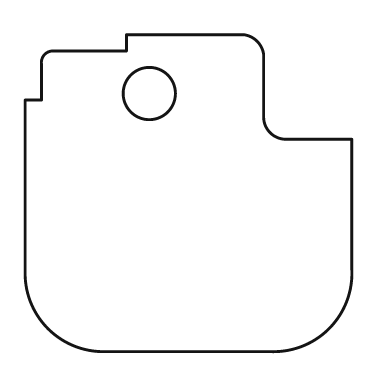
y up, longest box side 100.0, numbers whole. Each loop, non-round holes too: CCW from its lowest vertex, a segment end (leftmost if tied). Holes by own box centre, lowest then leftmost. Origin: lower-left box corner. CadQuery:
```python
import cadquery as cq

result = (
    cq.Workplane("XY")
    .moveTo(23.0, 0.0)
    .lineTo(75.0, 0.0)
    .threePointArc((93.0, 7.0), (100.0, 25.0))
    .lineTo(100.0, 65.0)
    .lineTo(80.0, 65.0)
    .threePointArc((75.0, 67.0), (73.0, 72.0))
    .lineTo(73.0, 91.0)
    .threePointArc((71.0, 95.0), (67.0, 97.0))
    .lineTo(31.0, 97.0)
    .lineTo(31.0, 92.0)
    .lineTo(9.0, 92.0)
    .threePointArc((6.0, 91.0), (5.0, 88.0))
    .lineTo(5.0, 77.0)
    .lineTo(0.0, 77.0)
    .lineTo(0.0, 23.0)
    .threePointArc((7.0, 7.0), (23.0, 0.0))
    .close()
    .moveTo(38.0, 79.0)
    .circle(8.0)
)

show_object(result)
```